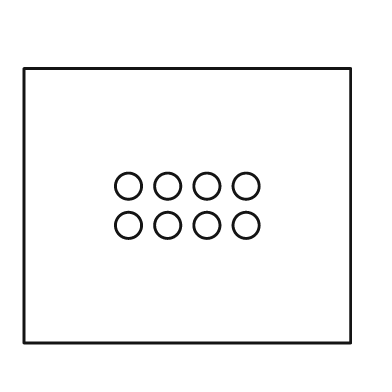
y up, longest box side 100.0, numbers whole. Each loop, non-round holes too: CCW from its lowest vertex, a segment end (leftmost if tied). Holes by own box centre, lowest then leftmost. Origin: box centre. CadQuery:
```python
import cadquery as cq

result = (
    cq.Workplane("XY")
    .moveTo(-50.0, -42.0)
    .lineTo(50.0, -42.0)
    .lineTo(50.0, 42.0)
    .lineTo(-50.0, 42.0)
    .close()
    .moveTo(-18.0, -6.0)
    .circle(4.0)
    .moveTo(-6.0, -6.0)
    .circle(4.0)
    .moveTo(6.0, -6.0)
    .circle(4.0)
    .moveTo(18.0, -6.0)
    .circle(4.0)
    .moveTo(-18.0, 6.0)
    .circle(4.0)
    .moveTo(-6.0, 6.0)
    .circle(4.0)
    .moveTo(6.0, 6.0)
    .circle(4.0)
    .moveTo(18.0, 6.0)
    .circle(4.0)
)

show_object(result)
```